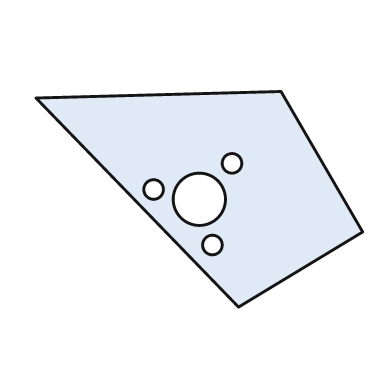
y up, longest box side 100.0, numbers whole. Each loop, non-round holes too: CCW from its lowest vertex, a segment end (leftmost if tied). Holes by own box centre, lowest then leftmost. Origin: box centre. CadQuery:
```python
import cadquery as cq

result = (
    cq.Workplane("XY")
    .moveTo(12.0, -33.0)
    .lineTo(50.0, -10.0)
    .lineTo(25.0, 33.0)
    .lineTo(-50.0, 31.0)
    .close()
    .moveTo(4.0, -14.0)
    .circle(3.0)
    .moveTo(0.0, 0.0)
    .circle(8.0)
    .moveTo(-14.0, 3.0)
    .circle(3.0)
    .moveTo(10.0, 11.0)
    .circle(3.0)
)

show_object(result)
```